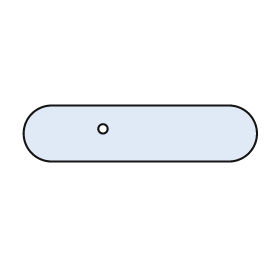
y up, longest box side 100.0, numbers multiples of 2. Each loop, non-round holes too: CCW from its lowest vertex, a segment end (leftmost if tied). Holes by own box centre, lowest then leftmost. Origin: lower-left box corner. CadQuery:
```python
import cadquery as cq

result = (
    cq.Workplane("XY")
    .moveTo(12.0, 0.0)
    .lineTo(88.0, 0.0)
    .threePointArc((100.0, 12.0), (88.0, 24.0))
    .lineTo(12.0, 24.0)
    .threePointArc((0.0, 12.0), (12.0, 0.0))
    .close()
    .moveTo(34.0, 14.0)
    .circle(2.0)
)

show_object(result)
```